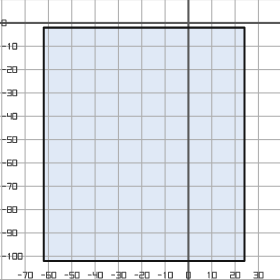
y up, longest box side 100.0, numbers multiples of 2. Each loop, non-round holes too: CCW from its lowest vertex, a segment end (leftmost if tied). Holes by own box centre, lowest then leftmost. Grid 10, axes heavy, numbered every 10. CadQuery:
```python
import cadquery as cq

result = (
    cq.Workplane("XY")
    .moveTo(-62.0, -102.0)
    .lineTo(24.0, -102.0)
    .lineTo(24.0, -2.0)
    .lineTo(-62.0, -2.0)
    .close()
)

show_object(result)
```